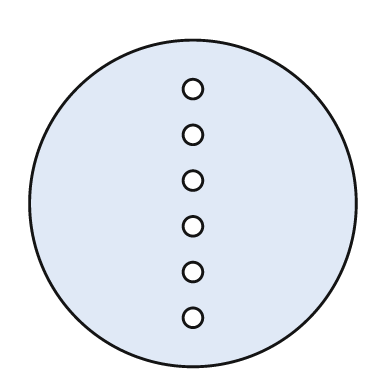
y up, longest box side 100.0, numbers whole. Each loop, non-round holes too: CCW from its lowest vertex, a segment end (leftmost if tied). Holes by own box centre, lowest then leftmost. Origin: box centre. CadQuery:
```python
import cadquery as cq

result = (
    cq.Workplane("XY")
    .moveTo(0.0, 0.0)
    .circle(50.0)
    .moveTo(0.0, -35.0)
    .circle(3.0)
    .moveTo(0.0, -21.0)
    .circle(3.0)
    .moveTo(0.0, -7.0)
    .circle(3.0)
    .moveTo(0.0, 7.0)
    .circle(3.0)
    .moveTo(0.0, 21.0)
    .circle(3.0)
    .moveTo(0.0, 35.0)
    .circle(3.0)
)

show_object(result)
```